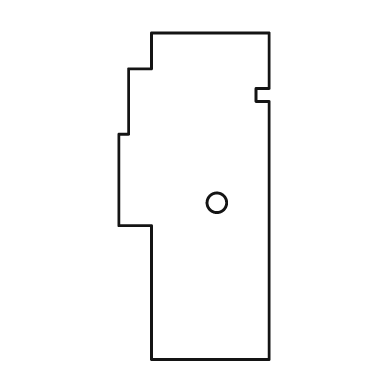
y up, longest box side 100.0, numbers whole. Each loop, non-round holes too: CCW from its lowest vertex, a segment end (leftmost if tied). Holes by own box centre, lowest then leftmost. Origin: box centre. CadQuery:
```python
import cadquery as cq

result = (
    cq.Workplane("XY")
    .moveTo(-13.0, -50.0)
    .lineTo(23.0, -50.0)
    .lineTo(23.0, 29.0)
    .lineTo(19.0, 29.0)
    .lineTo(19.0, 33.0)
    .lineTo(23.0, 33.0)
    .lineTo(23.0, 50.0)
    .lineTo(-13.0, 50.0)
    .lineTo(-13.0, 39.0)
    .lineTo(-20.0, 39.0)
    .lineTo(-20.0, 19.0)
    .lineTo(-23.0, 19.0)
    .lineTo(-23.0, -9.0)
    .lineTo(-13.0, -9.0)
    .close()
    .moveTo(7.0, -2.0)
    .circle(3.0)
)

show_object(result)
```